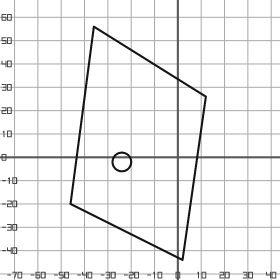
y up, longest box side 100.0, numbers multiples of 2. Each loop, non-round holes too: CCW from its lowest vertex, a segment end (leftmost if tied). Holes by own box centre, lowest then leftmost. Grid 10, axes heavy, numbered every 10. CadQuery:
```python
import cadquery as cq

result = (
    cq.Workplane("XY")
    .moveTo(2.0, -44.0)
    .lineTo(12.0, 26.0)
    .lineTo(-36.0, 56.0)
    .lineTo(-46.0, -20.0)
    .close()
    .moveTo(-24.0, -2.0)
    .circle(4.0)
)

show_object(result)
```